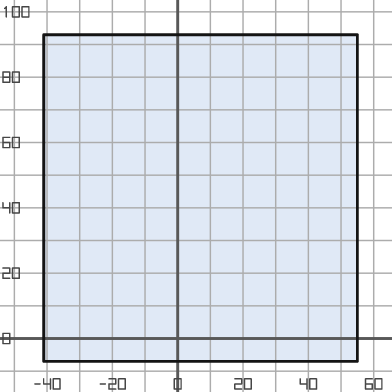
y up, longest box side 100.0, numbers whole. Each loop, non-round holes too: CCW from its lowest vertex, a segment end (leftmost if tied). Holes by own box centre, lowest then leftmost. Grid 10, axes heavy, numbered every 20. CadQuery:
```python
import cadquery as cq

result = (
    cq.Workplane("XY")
    .moveTo(-41.0, -7.0)
    .lineTo(55.0, -7.0)
    .lineTo(55.0, 93.0)
    .lineTo(-41.0, 93.0)
    .close()
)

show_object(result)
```